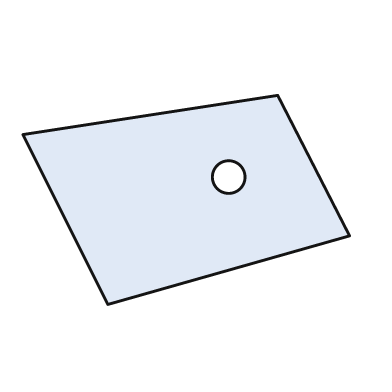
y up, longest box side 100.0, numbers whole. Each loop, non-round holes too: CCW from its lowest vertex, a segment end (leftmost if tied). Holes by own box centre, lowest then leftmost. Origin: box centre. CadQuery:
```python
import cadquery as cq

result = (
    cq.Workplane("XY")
    .moveTo(-24.0, -32.0)
    .lineTo(50.0, -11.0)
    .lineTo(28.0, 32.0)
    .lineTo(-50.0, 20.0)
    .close()
    .moveTo(13.0, 7.0)
    .circle(5.0)
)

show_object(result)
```